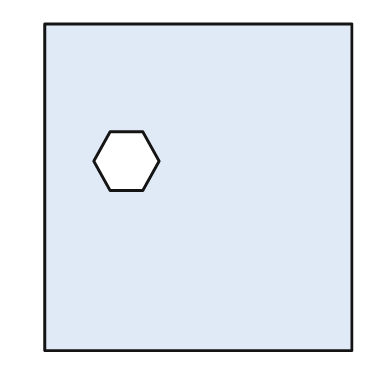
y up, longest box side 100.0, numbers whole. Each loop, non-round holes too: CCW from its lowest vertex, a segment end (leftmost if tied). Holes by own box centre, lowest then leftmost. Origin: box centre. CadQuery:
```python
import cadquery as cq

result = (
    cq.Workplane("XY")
    .moveTo(-47.0, -50.0)
    .lineTo(47.0, -50.0)
    .lineTo(47.0, 50.0)
    .lineTo(-47.0, 50.0)
    .close()
    .moveTo(-27.0, -1.0)
    .lineTo(-17.0, -1.0)
    .lineTo(-12.0, 8.0)
    .lineTo(-17.0, 17.0)
    .lineTo(-27.0, 17.0)
    .lineTo(-32.0, 8.0)
    .close()
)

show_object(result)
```